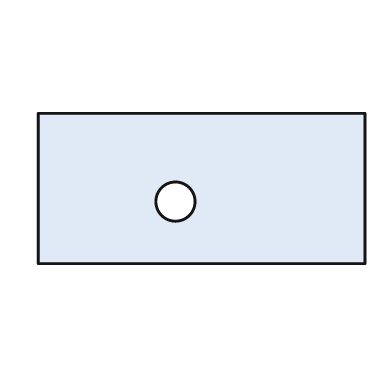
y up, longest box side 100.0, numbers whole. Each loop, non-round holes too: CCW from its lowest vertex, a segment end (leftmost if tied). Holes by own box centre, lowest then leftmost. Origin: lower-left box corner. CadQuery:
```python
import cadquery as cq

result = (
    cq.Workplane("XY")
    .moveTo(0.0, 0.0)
    .lineTo(100.0, 0.0)
    .lineTo(100.0, 46.0)
    .lineTo(0.0, 46.0)
    .close()
    .moveTo(42.0, 19.0)
    .circle(6.0)
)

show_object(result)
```